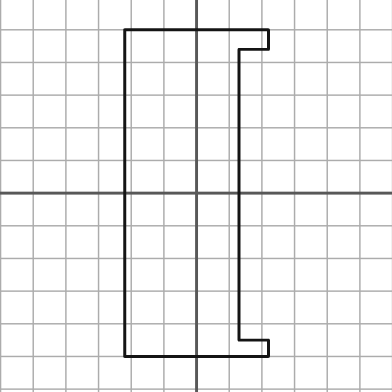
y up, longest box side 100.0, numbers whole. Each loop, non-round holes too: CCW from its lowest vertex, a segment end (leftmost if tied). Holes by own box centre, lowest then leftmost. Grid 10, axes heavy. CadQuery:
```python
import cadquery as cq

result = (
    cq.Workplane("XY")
    .moveTo(-22.0, -50.0)
    .lineTo(22.0, -50.0)
    .lineTo(22.0, -45.0)
    .lineTo(13.0, -45.0)
    .lineTo(13.0, 44.0)
    .lineTo(22.0, 44.0)
    .lineTo(22.0, 50.0)
    .lineTo(-22.0, 50.0)
    .close()
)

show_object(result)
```